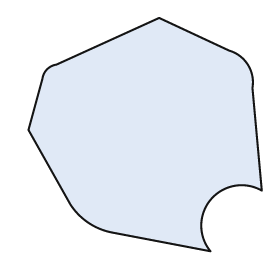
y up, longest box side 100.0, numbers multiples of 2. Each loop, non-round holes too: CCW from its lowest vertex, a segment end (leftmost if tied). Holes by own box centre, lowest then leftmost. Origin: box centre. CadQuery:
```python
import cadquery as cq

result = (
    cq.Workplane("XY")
    .moveTo(28.0, -50.0)
    .threePointArc((28.0, -28.0), (50.0, -24.0))
    .lineTo(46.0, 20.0)
    .threePointArc((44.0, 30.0), (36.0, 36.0))
    .lineTo(6.0, 50.0)
    .lineTo(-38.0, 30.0)
    .threePointArc((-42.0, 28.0), (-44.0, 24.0))
    .lineTo(-50.0, 2.0)
    .lineTo(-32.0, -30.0)
    .threePointArc((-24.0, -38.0), (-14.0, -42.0))
    .close()
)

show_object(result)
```